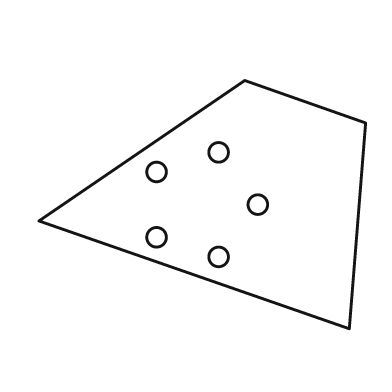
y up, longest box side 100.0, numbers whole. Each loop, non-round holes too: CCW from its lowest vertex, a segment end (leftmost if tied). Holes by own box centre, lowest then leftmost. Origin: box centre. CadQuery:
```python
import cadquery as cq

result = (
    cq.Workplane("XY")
    .moveTo(45.0, -38.0)
    .lineTo(50.0, 25.0)
    .lineTo(13.0, 38.0)
    .lineTo(-50.0, -5.0)
    .close()
    .moveTo(5.0, -16.0)
    .circle(3.0)
    .moveTo(-14.0, -10.0)
    .circle(3.0)
    .moveTo(17.0, 0.0)
    .circle(3.0)
    .moveTo(-14.0, 10.0)
    .circle(3.0)
    .moveTo(5.0, 16.0)
    .circle(3.0)
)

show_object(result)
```